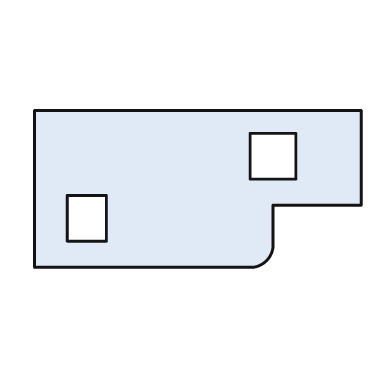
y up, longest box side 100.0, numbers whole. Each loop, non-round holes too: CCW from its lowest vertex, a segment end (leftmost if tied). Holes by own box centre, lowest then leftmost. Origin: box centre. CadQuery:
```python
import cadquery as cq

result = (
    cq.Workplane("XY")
    .moveTo(-50.0, -24.0)
    .lineTo(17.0, -24.0)
    .threePointArc((21.0, -22.0), (23.0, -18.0))
    .lineTo(23.0, -5.0)
    .lineTo(50.0, -5.0)
    .lineTo(50.0, 24.0)
    .lineTo(-50.0, 24.0)
    .close()
    .moveTo(-40.0, -16.0)
    .lineTo(-28.0, -16.0)
    .lineTo(-28.0, -2.0)
    .lineTo(-40.0, -2.0)
    .close()
    .moveTo(16.0, 3.0)
    .lineTo(30.0, 3.0)
    .lineTo(30.0, 17.0)
    .lineTo(16.0, 17.0)
    .close()
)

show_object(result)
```